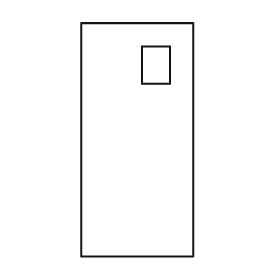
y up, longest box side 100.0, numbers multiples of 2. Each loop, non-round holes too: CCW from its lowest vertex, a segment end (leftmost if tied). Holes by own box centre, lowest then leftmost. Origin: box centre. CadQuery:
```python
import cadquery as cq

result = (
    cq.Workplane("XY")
    .moveTo(-24.0, -50.0)
    .lineTo(24.0, -50.0)
    .lineTo(24.0, 50.0)
    .lineTo(-24.0, 50.0)
    .close()
    .moveTo(2.0, 24.0)
    .lineTo(14.0, 24.0)
    .lineTo(14.0, 40.0)
    .lineTo(2.0, 40.0)
    .close()
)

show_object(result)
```